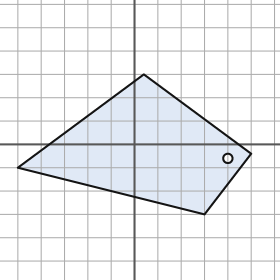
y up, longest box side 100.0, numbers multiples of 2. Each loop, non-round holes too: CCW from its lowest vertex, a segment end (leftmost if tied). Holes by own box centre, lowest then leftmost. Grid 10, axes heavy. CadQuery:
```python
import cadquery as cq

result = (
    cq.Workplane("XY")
    .moveTo(30.0, -30.0)
    .lineTo(50.0, -4.0)
    .lineTo(4.0, 30.0)
    .lineTo(-50.0, -10.0)
    .close()
    .moveTo(40.0, -6.0)
    .circle(2.0)
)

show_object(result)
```